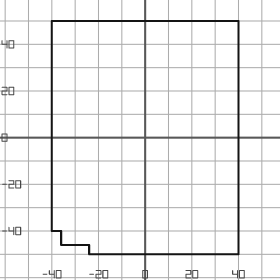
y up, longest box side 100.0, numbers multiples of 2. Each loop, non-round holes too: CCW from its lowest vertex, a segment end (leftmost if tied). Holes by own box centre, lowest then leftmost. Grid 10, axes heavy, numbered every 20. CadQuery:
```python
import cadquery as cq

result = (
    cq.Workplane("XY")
    .moveTo(-24.0, -50.0)
    .lineTo(40.0, -50.0)
    .lineTo(40.0, 50.0)
    .lineTo(-40.0, 50.0)
    .lineTo(-40.0, -40.0)
    .lineTo(-36.0, -40.0)
    .lineTo(-36.0, -46.0)
    .lineTo(-24.0, -46.0)
    .close()
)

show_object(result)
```